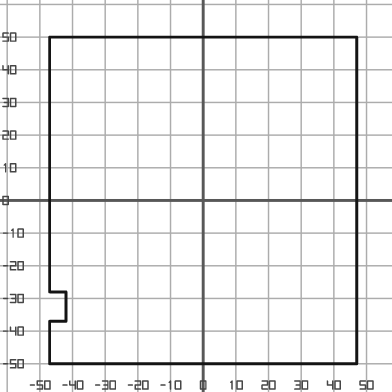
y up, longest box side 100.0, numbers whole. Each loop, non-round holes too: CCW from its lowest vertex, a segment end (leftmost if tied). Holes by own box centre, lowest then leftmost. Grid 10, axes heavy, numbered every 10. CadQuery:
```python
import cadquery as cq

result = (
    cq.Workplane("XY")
    .moveTo(-47.0, -50.0)
    .lineTo(47.0, -50.0)
    .lineTo(47.0, 50.0)
    .lineTo(-47.0, 50.0)
    .lineTo(-47.0, -28.0)
    .lineTo(-42.0, -28.0)
    .lineTo(-42.0, -37.0)
    .lineTo(-47.0, -37.0)
    .close()
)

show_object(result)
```